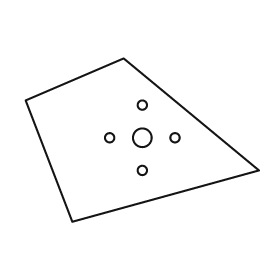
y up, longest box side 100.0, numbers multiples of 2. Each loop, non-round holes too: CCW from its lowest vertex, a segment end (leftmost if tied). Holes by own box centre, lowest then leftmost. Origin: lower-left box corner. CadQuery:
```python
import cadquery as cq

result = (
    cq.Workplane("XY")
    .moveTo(20.0, 0.0)
    .lineTo(100.0, 22.0)
    .lineTo(42.0, 70.0)
    .lineTo(0.0, 52.0)
    .close()
    .moveTo(50.0, 22.0)
    .circle(2.0)
    .moveTo(36.0, 36.0)
    .circle(2.0)
    .moveTo(50.0, 36.0)
    .circle(4.0)
    .moveTo(64.0, 36.0)
    .circle(2.0)
    .moveTo(50.0, 50.0)
    .circle(2.0)
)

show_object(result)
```